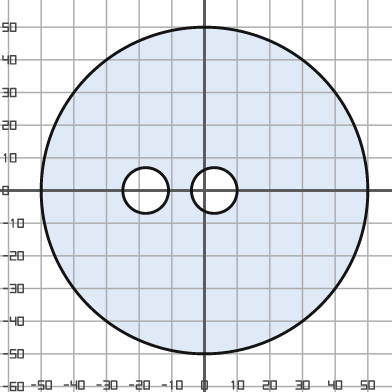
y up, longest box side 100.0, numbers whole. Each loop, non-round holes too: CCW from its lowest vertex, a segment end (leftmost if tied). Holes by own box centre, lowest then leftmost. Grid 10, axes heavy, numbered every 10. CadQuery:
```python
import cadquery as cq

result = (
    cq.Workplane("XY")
    .moveTo(0.0, 0.0)
    .circle(50.0)
    .moveTo(-18.0, 0.0)
    .circle(7.0)
    .moveTo(3.0, 0.0)
    .circle(7.0)
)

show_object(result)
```